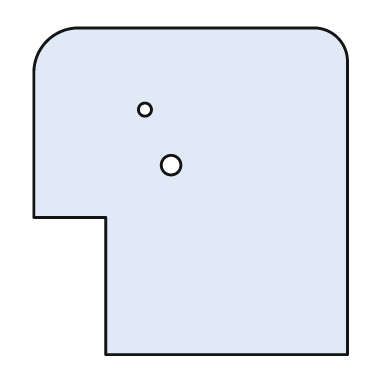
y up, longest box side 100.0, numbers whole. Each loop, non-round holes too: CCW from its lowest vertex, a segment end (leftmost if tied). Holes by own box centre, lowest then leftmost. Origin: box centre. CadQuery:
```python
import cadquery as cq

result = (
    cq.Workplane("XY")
    .moveTo(-26.0, -50.0)
    .lineTo(48.0, -50.0)
    .lineTo(48.0, 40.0)
    .threePointArc((45.0, 47.0), (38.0, 50.0))
    .lineTo(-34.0, 50.0)
    .threePointArc((-44.0, 46.0), (-48.0, 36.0))
    .lineTo(-48.0, -8.0)
    .lineTo(-26.0, -8.0)
    .close()
    .moveTo(-6.0, 8.0)
    .circle(3.0)
    .moveTo(-14.0, 25.0)
    .circle(2.0)
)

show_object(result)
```